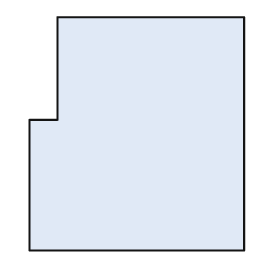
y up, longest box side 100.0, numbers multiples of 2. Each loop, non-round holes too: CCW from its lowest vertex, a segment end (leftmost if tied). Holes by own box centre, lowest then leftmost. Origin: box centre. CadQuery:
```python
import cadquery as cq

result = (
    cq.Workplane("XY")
    .moveTo(-46.0, -50.0)
    .lineTo(46.0, -50.0)
    .lineTo(46.0, 50.0)
    .lineTo(-34.0, 50.0)
    .lineTo(-34.0, 6.0)
    .lineTo(-46.0, 6.0)
    .close()
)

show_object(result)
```